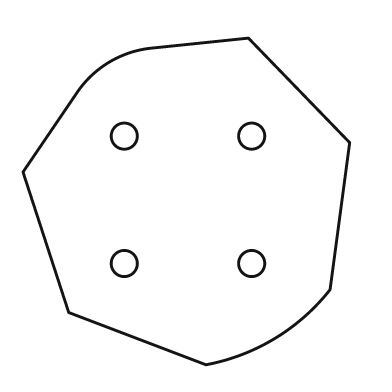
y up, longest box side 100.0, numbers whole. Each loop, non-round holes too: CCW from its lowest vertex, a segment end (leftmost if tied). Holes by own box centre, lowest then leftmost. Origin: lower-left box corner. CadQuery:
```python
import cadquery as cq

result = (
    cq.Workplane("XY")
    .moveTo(56.0, 0.0)
    .threePointArc((77.0, 8.0), (94.0, 23.0))
    .lineTo(100.0, 68.0)
    .lineTo(69.0, 100.0)
    .lineTo(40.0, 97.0)
    .threePointArc((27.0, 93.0), (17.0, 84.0))
    .lineTo(0.0, 59.0)
    .lineTo(14.0, 16.0)
    .close()
    .moveTo(31.0, 31.0)
    .circle(4.0)
    .moveTo(70.0, 31.0)
    .circle(4.0)
    .moveTo(31.0, 70.0)
    .circle(4.0)
    .moveTo(70.0, 70.0)
    .circle(4.0)
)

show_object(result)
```